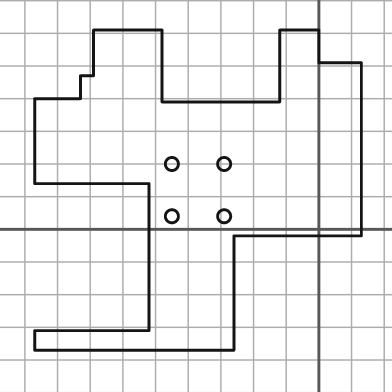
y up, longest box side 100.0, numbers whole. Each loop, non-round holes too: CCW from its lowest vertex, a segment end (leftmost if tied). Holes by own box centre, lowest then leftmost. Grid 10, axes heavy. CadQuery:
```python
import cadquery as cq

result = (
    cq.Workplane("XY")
    .moveTo(-87.0, -37.0)
    .lineTo(-26.0, -37.0)
    .lineTo(-26.0, -2.0)
    .lineTo(13.0, -2.0)
    .lineTo(13.0, 51.0)
    .lineTo(0.0, 51.0)
    .lineTo(0.0, 61.0)
    .lineTo(-12.0, 61.0)
    .lineTo(-12.0, 39.0)
    .lineTo(-48.0, 39.0)
    .lineTo(-48.0, 61.0)
    .lineTo(-69.0, 61.0)
    .lineTo(-69.0, 47.0)
    .lineTo(-73.0, 47.0)
    .lineTo(-73.0, 40.0)
    .lineTo(-87.0, 40.0)
    .lineTo(-87.0, 14.0)
    .lineTo(-52.0, 14.0)
    .lineTo(-52.0, -31.0)
    .lineTo(-87.0, -31.0)
    .close()
    .moveTo(-45.0, 4.0)
    .circle(2.0)
    .moveTo(-29.0, 4.0)
    .circle(2.0)
    .moveTo(-45.0, 20.0)
    .circle(2.0)
    .moveTo(-29.0, 20.0)
    .circle(2.0)
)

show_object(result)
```